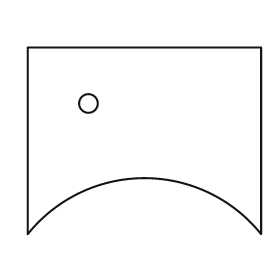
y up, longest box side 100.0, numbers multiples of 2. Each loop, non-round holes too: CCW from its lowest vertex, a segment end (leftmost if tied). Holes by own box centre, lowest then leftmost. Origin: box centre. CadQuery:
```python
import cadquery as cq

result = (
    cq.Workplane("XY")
    .moveTo(-50.0, -40.0)
    .threePointArc((0.0, -16.0), (50.0, -40.0))
    .lineTo(50.0, 40.0)
    .lineTo(-50.0, 40.0)
    .close()
    .moveTo(-24.0, 16.0)
    .circle(4.0)
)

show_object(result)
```